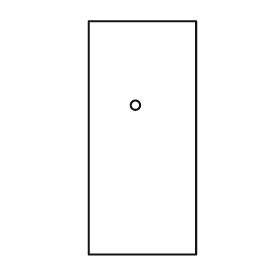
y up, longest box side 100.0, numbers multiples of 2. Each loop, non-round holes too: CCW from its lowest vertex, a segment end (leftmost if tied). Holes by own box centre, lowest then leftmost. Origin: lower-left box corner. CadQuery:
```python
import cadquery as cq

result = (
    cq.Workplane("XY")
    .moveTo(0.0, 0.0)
    .lineTo(46.0, 0.0)
    .lineTo(46.0, 100.0)
    .lineTo(0.0, 100.0)
    .close()
    .moveTo(20.0, 64.0)
    .circle(2.0)
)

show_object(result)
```